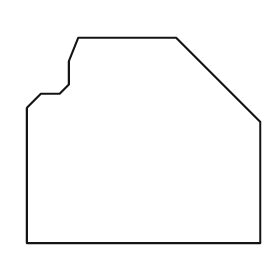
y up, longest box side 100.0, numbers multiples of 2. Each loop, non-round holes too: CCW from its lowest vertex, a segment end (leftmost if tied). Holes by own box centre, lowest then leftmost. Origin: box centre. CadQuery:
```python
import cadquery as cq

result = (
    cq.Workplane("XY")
    .moveTo(-50.0, -44.0)
    .lineTo(50.0, -44.0)
    .lineTo(50.0, 8.0)
    .lineTo(14.0, 44.0)
    .lineTo(-28.0, 44.0)
    .lineTo(-32.0, 34.0)
    .lineTo(-32.0, 24.0)
    .lineTo(-36.0, 20.0)
    .lineTo(-44.0, 20.0)
    .lineTo(-50.0, 14.0)
    .close()
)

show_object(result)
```